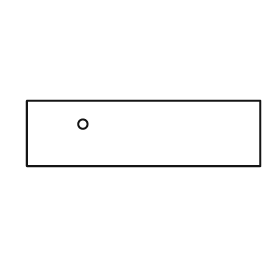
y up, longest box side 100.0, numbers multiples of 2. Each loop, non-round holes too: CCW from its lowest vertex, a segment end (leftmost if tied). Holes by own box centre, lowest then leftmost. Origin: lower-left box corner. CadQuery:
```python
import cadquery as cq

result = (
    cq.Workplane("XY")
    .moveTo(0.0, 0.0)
    .lineTo(100.0, 0.0)
    .lineTo(100.0, 28.0)
    .lineTo(0.0, 28.0)
    .close()
    .moveTo(24.0, 18.0)
    .circle(2.0)
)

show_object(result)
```